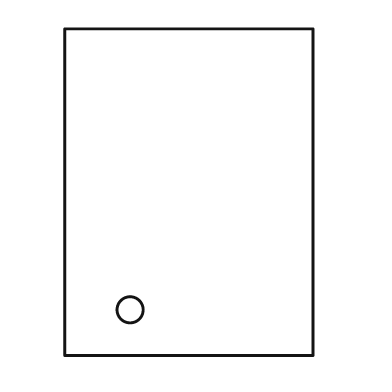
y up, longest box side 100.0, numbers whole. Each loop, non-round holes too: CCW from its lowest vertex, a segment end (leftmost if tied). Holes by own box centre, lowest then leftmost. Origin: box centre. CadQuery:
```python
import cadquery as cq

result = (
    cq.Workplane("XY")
    .moveTo(-38.0, -50.0)
    .lineTo(38.0, -50.0)
    .lineTo(38.0, 50.0)
    .lineTo(-38.0, 50.0)
    .close()
    .moveTo(-18.0, -36.0)
    .circle(4.0)
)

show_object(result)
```